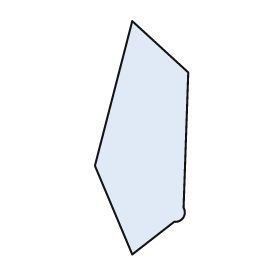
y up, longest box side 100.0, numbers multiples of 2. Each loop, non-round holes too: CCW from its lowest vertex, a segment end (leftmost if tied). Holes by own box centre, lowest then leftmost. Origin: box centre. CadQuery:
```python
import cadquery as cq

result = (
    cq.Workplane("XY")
    .moveTo(-4.0, -50.0)
    .lineTo(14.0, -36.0)
    .threePointArc((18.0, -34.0), (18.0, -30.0))
    .lineTo(20.0, 28.0)
    .lineTo(-4.0, 50.0)
    .lineTo(-20.0, -12.0)
    .close()
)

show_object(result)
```